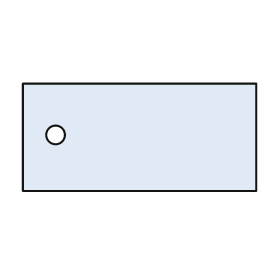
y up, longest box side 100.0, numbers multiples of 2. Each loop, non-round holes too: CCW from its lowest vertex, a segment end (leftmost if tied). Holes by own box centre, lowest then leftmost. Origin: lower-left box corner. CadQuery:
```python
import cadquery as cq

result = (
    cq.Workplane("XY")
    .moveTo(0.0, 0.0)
    .lineTo(100.0, 0.0)
    .lineTo(100.0, 46.0)
    .lineTo(0.0, 46.0)
    .close()
    .moveTo(14.0, 24.0)
    .circle(4.0)
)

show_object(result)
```